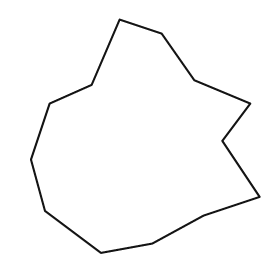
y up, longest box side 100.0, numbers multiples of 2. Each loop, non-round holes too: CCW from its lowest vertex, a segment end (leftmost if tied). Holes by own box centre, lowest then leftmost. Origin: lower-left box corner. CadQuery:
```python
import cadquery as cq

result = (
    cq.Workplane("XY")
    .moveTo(30.0, 0.0)
    .lineTo(52.0, 4.0)
    .lineTo(74.0, 16.0)
    .lineTo(98.0, 24.0)
    .lineTo(82.0, 48.0)
    .lineTo(94.0, 64.0)
    .lineTo(70.0, 74.0)
    .lineTo(56.0, 94.0)
    .lineTo(38.0, 100.0)
    .lineTo(26.0, 72.0)
    .lineTo(8.0, 64.0)
    .lineTo(0.0, 40.0)
    .lineTo(6.0, 18.0)
    .close()
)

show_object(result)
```